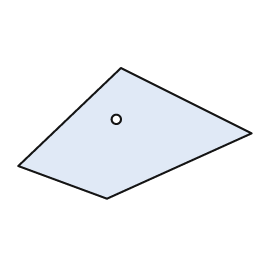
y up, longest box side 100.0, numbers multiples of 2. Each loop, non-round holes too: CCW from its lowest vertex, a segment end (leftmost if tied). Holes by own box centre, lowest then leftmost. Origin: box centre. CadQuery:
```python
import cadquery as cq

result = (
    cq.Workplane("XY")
    .moveTo(-12.0, -28.0)
    .lineTo(50.0, 0.0)
    .lineTo(-6.0, 28.0)
    .lineTo(-50.0, -14.0)
    .close()
    .moveTo(-8.0, 6.0)
    .circle(2.0)
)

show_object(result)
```